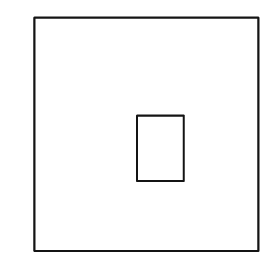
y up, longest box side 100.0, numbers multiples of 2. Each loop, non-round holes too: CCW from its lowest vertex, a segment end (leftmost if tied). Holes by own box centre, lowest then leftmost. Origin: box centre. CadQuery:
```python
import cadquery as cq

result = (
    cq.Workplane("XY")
    .moveTo(-48.0, -50.0)
    .lineTo(48.0, -50.0)
    .lineTo(48.0, 50.0)
    .lineTo(-48.0, 50.0)
    .close()
    .moveTo(-4.0, -20.0)
    .lineTo(16.0, -20.0)
    .lineTo(16.0, 8.0)
    .lineTo(-4.0, 8.0)
    .close()
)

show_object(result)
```